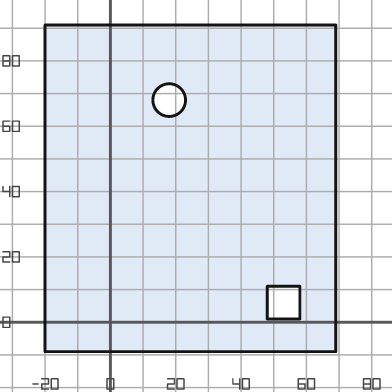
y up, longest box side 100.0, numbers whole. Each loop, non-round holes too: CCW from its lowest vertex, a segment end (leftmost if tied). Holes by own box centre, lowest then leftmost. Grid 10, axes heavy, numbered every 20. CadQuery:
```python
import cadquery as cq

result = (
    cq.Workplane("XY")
    .moveTo(-20.0, -9.0)
    .lineTo(69.0, -9.0)
    .lineTo(69.0, 91.0)
    .lineTo(-20.0, 91.0)
    .close()
    .moveTo(48.0, 1.0)
    .lineTo(58.0, 1.0)
    .lineTo(58.0, 11.0)
    .lineTo(48.0, 11.0)
    .close()
    .moveTo(18.0, 68.0)
    .circle(5.0)
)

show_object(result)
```